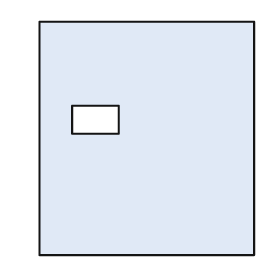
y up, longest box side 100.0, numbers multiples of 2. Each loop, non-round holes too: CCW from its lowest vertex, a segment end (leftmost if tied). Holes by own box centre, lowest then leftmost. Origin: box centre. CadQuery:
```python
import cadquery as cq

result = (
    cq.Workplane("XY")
    .moveTo(-46.0, -50.0)
    .lineTo(46.0, -50.0)
    .lineTo(46.0, 50.0)
    .lineTo(-46.0, 50.0)
    .close()
    .moveTo(-32.0, 2.0)
    .lineTo(-12.0, 2.0)
    .lineTo(-12.0, 14.0)
    .lineTo(-32.0, 14.0)
    .close()
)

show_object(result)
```